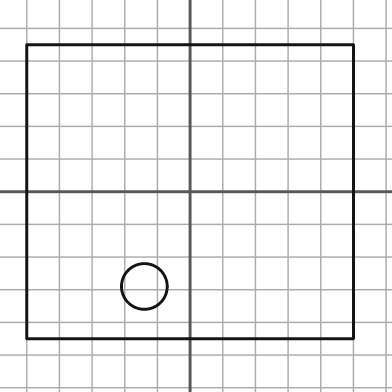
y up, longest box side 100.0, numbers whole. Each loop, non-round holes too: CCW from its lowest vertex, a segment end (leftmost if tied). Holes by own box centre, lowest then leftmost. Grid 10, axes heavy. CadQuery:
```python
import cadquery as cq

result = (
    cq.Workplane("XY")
    .moveTo(-50.0, -45.0)
    .lineTo(50.0, -45.0)
    .lineTo(50.0, 45.0)
    .lineTo(-50.0, 45.0)
    .close()
    .moveTo(-14.0, -29.0)
    .circle(7.0)
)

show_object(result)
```